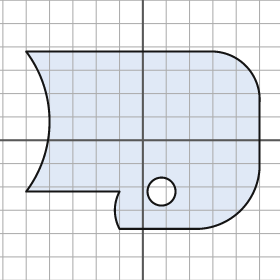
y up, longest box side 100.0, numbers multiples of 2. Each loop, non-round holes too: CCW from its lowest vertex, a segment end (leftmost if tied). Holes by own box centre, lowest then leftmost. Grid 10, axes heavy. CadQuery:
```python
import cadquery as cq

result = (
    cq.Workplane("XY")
    .moveTo(-10.0, -38.0)
    .lineTo(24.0, -38.0)
    .threePointArc((42.0, -30.0), (50.0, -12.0))
    .lineTo(50.0, 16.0)
    .threePointArc((44.0, 32.0), (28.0, 38.0))
    .lineTo(-50.0, 38.0)
    .threePointArc((-40.0, 8.0), (-50.0, -22.0))
    .lineTo(-10.0, -22.0)
    .threePointArc((-12.0, -30.0), (-10.0, -38.0))
    .close()
    .moveTo(8.0, -22.0)
    .circle(6.0)
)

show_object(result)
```